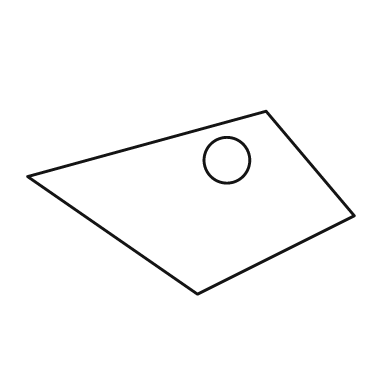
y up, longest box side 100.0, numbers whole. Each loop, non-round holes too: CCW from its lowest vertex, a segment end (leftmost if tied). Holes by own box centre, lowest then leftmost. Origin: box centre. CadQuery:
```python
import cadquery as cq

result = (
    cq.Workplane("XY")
    .moveTo(2.0, -28.0)
    .lineTo(50.0, -4.0)
    .lineTo(23.0, 28.0)
    .lineTo(-50.0, 8.0)
    .close()
    .moveTo(11.0, 13.0)
    .circle(7.0)
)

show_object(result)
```